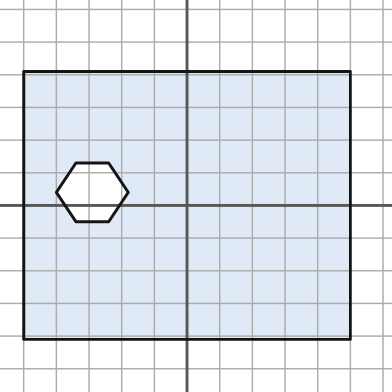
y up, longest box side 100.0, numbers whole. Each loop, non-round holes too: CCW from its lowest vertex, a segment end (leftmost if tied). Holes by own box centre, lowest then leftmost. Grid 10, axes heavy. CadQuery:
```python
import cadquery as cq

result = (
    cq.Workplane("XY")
    .moveTo(-50.0, -41.0)
    .lineTo(50.0, -41.0)
    .lineTo(50.0, 41.0)
    .lineTo(-50.0, 41.0)
    .close()
    .moveTo(-34.0, -5.0)
    .lineTo(-24.0, -5.0)
    .lineTo(-18.0, 4.0)
    .lineTo(-24.0, 13.0)
    .lineTo(-34.0, 13.0)
    .lineTo(-40.0, 4.0)
    .close()
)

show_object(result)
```